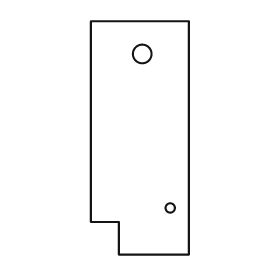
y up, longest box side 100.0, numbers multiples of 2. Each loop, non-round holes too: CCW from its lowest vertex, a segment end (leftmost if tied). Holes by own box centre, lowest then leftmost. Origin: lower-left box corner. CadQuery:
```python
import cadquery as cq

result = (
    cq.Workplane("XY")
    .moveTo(12.0, 0.0)
    .lineTo(42.0, 0.0)
    .lineTo(42.0, 100.0)
    .lineTo(0.0, 100.0)
    .lineTo(0.0, 14.0)
    .lineTo(12.0, 14.0)
    .close()
    .moveTo(34.0, 20.0)
    .circle(2.0)
    .moveTo(22.0, 86.0)
    .circle(4.0)
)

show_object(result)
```